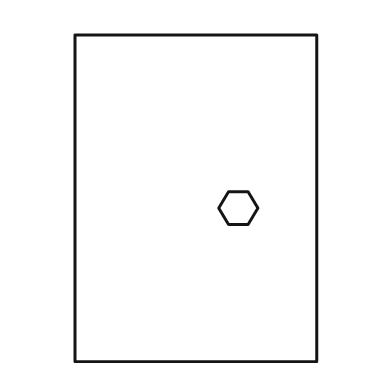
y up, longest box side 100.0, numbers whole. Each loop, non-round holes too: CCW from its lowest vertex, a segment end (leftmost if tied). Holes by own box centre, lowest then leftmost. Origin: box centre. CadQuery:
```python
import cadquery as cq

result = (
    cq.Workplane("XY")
    .moveTo(-37.0, -50.0)
    .lineTo(37.0, -50.0)
    .lineTo(37.0, 50.0)
    .lineTo(-37.0, 50.0)
    .close()
    .moveTo(10.0, -8.0)
    .lineTo(16.0, -8.0)
    .lineTo(19.0, -3.0)
    .lineTo(16.0, 2.0)
    .lineTo(10.0, 2.0)
    .lineTo(7.0, -3.0)
    .close()
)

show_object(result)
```